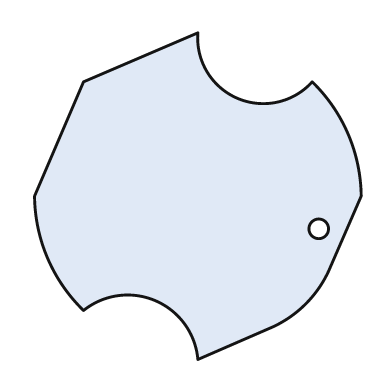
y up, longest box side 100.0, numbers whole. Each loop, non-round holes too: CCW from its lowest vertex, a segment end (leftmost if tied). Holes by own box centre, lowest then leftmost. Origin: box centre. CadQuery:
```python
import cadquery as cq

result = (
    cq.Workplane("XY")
    .moveTo(0.0, -50.0)
    .lineTo(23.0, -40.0)
    .threePointArc((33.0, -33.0), (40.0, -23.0))
    .lineTo(50.0, 0.0)
    .threePointArc((46.0, 19.0), (35.0, 35.0))
    .threePointArc((12.0, 30.0), (0.0, 50.0))
    .lineTo(-35.0, 35.0)
    .lineTo(-50.0, 0.0)
    .threePointArc((-46.0, -19.0), (-35.0, -35.0))
    .threePointArc((-13.0, -32.0), (0.0, -50.0))
    .close()
    .moveTo(37.0, -10.0)
    .circle(3.0)
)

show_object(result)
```